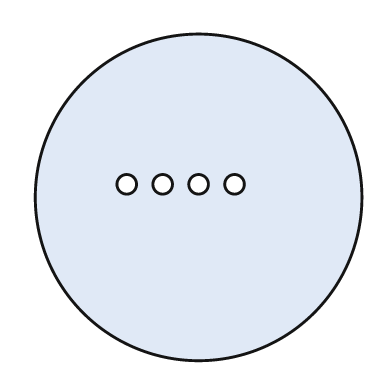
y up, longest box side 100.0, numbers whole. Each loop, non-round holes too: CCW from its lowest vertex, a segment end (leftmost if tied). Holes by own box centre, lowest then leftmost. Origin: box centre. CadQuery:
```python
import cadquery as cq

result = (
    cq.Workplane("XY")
    .moveTo(0.0, 0.0)
    .circle(50.0)
    .moveTo(-22.0, 4.0)
    .circle(3.0)
    .moveTo(-11.0, 4.0)
    .circle(3.0)
    .moveTo(0.0, 4.0)
    .circle(3.0)
    .moveTo(11.0, 4.0)
    .circle(3.0)
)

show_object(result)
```